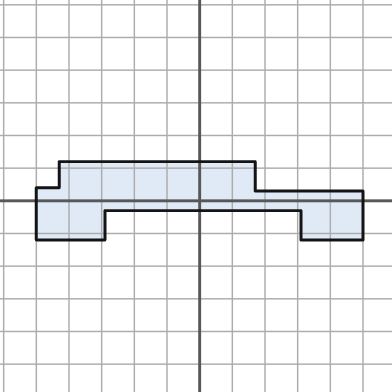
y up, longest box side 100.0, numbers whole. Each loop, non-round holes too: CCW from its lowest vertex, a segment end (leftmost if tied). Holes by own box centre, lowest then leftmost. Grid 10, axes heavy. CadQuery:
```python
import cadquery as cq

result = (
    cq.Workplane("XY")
    .moveTo(-50.0, -12.0)
    .lineTo(-29.0, -12.0)
    .lineTo(-29.0, -3.0)
    .lineTo(31.0, -3.0)
    .lineTo(31.0, -12.0)
    .lineTo(50.0, -12.0)
    .lineTo(50.0, 3.0)
    .lineTo(17.0, 3.0)
    .lineTo(17.0, 12.0)
    .lineTo(-43.0, 12.0)
    .lineTo(-43.0, 4.0)
    .lineTo(-50.0, 4.0)
    .close()
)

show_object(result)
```